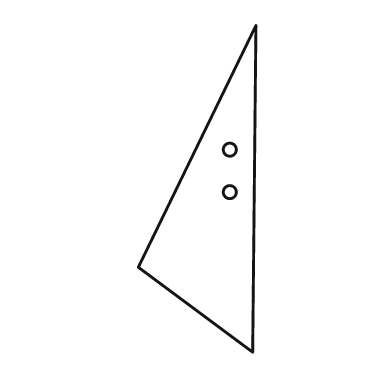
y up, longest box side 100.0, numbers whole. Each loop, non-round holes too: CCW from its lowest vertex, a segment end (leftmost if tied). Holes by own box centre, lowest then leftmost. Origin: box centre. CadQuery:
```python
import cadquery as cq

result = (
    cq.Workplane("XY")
    .moveTo(17.0, -50.0)
    .lineTo(18.0, 50.0)
    .lineTo(-18.0, -24.0)
    .close()
    .moveTo(10.0, -1.0)
    .circle(2.0)
    .moveTo(10.0, 12.0)
    .circle(2.0)
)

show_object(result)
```